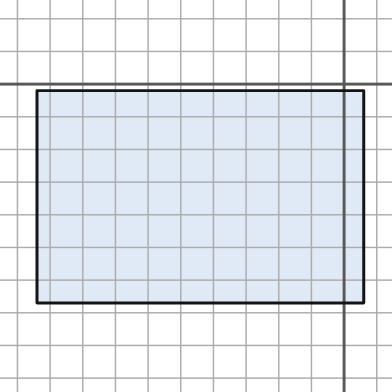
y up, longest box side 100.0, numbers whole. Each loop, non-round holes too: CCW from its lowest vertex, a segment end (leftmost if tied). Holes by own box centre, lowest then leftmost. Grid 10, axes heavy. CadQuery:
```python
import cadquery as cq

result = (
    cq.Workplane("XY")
    .moveTo(-94.0, -67.0)
    .lineTo(6.0, -67.0)
    .lineTo(6.0, -2.0)
    .lineTo(-94.0, -2.0)
    .close()
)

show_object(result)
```